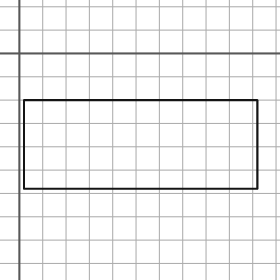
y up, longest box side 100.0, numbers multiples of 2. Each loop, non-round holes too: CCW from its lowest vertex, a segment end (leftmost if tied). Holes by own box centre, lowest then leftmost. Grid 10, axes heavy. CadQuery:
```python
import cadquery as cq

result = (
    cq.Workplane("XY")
    .moveTo(2.0, -58.0)
    .lineTo(102.0, -58.0)
    .lineTo(102.0, -20.0)
    .lineTo(2.0, -20.0)
    .close()
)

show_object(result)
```